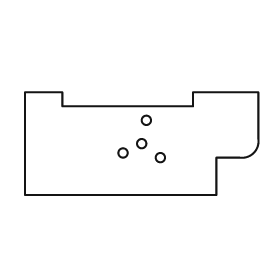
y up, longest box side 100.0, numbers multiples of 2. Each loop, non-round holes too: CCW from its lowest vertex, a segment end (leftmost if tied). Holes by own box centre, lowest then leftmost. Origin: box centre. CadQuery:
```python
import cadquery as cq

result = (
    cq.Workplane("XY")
    .moveTo(-50.0, -22.0)
    .lineTo(32.0, -22.0)
    .lineTo(32.0, -6.0)
    .lineTo(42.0, -6.0)
    .threePointArc((48.0, -4.0), (50.0, 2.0))
    .lineTo(50.0, 22.0)
    .lineTo(22.0, 22.0)
    .lineTo(22.0, 16.0)
    .lineTo(-34.0, 16.0)
    .lineTo(-34.0, 22.0)
    .lineTo(-50.0, 22.0)
    .close()
    .moveTo(8.0, -6.0)
    .circle(2.0)
    .moveTo(-8.0, -4.0)
    .circle(2.0)
    .moveTo(0.0, 0.0)
    .circle(2.0)
    .moveTo(2.0, 10.0)
    .circle(2.0)
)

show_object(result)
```